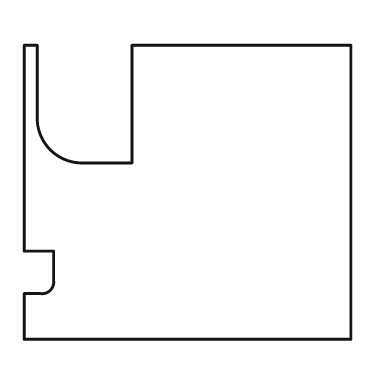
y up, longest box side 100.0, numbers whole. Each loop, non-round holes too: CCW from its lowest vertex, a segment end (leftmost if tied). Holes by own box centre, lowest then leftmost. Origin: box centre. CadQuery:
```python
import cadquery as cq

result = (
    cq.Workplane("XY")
    .moveTo(-50.0, -45.0)
    .lineTo(50.0, -45.0)
    .lineTo(50.0, 45.0)
    .lineTo(-17.0, 45.0)
    .lineTo(-17.0, 9.0)
    .lineTo(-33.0, 9.0)
    .threePointArc((-42.0, 13.0), (-46.0, 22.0))
    .lineTo(-46.0, 45.0)
    .lineTo(-50.0, 45.0)
    .lineTo(-50.0, -18.0)
    .lineTo(-41.0, -18.0)
    .lineTo(-41.0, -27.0)
    .threePointArc((-42.0, -30.0), (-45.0, -31.0))
    .lineTo(-50.0, -31.0)
    .close()
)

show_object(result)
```